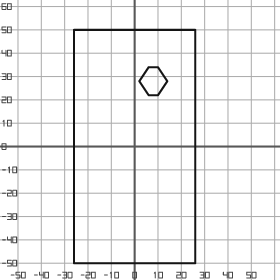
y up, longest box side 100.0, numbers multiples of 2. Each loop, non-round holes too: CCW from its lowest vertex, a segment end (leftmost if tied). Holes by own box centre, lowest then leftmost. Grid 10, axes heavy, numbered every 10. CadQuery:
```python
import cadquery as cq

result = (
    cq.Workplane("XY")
    .moveTo(-26.0, -50.0)
    .lineTo(26.0, -50.0)
    .lineTo(26.0, 50.0)
    .lineTo(-26.0, 50.0)
    .close()
    .moveTo(6.0, 22.0)
    .lineTo(10.0, 22.0)
    .lineTo(14.0, 28.0)
    .lineTo(10.0, 34.0)
    .lineTo(6.0, 34.0)
    .lineTo(2.0, 28.0)
    .close()
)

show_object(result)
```